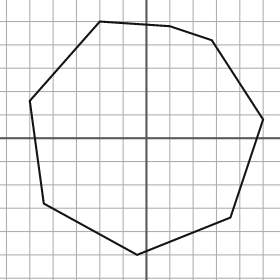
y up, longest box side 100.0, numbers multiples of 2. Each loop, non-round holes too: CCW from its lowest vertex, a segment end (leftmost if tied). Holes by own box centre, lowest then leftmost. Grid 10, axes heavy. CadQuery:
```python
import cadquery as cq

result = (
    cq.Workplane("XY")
    .moveTo(-4.0, -50.0)
    .lineTo(36.0, -34.0)
    .lineTo(50.0, 8.0)
    .lineTo(28.0, 42.0)
    .lineTo(10.0, 48.0)
    .lineTo(-20.0, 50.0)
    .lineTo(-50.0, 16.0)
    .lineTo(-44.0, -28.0)
    .close()
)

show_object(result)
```